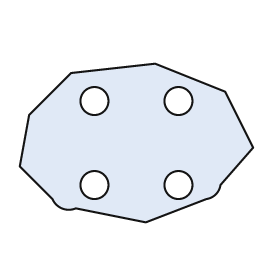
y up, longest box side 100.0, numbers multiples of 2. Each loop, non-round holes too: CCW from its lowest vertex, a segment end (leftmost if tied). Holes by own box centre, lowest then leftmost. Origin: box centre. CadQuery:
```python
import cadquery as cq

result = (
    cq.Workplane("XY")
    .moveTo(4.0, -34.0)
    .lineTo(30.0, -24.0)
    .threePointArc((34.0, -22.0), (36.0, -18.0))
    .lineTo(50.0, -2.0)
    .lineTo(38.0, 22.0)
    .lineTo(8.0, 34.0)
    .lineTo(-28.0, 30.0)
    .lineTo(-46.0, 12.0)
    .lineTo(-50.0, -10.0)
    .lineTo(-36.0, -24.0)
    .threePointArc((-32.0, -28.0), (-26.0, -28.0))
    .close()
    .moveTo(-18.0, -18.0)
    .circle(6.0)
    .moveTo(18.0, -18.0)
    .circle(6.0)
    .moveTo(-18.0, 18.0)
    .circle(6.0)
    .moveTo(18.0, 18.0)
    .circle(6.0)
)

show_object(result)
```